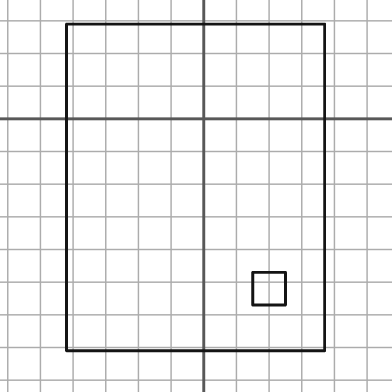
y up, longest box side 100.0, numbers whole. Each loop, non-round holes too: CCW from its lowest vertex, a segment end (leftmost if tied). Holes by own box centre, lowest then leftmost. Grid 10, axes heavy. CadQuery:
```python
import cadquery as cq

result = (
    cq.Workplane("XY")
    .moveTo(-42.0, -71.0)
    .lineTo(37.0, -71.0)
    .lineTo(37.0, 29.0)
    .lineTo(-42.0, 29.0)
    .close()
    .moveTo(15.0, -57.0)
    .lineTo(25.0, -57.0)
    .lineTo(25.0, -47.0)
    .lineTo(15.0, -47.0)
    .close()
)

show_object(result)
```